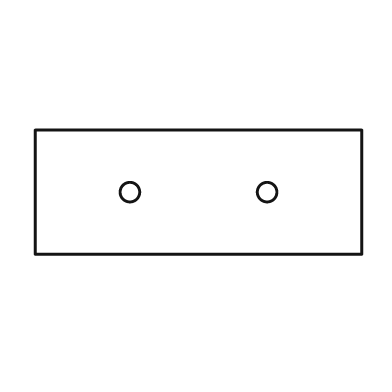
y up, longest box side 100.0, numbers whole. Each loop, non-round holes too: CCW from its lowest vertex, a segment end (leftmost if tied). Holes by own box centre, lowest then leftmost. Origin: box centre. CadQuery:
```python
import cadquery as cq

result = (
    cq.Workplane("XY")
    .moveTo(-50.0, -19.0)
    .lineTo(50.0, -19.0)
    .lineTo(50.0, 19.0)
    .lineTo(-50.0, 19.0)
    .close()
    .moveTo(-21.0, 0.0)
    .circle(3.0)
    .moveTo(21.0, 0.0)
    .circle(3.0)
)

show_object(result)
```